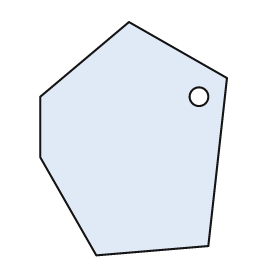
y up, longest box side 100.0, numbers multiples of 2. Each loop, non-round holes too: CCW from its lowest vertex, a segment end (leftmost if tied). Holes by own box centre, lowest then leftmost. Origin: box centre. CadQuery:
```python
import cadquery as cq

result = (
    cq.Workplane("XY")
    .moveTo(-16.0, -50.0)
    .lineTo(32.0, -46.0)
    .lineTo(40.0, 26.0)
    .lineTo(-2.0, 50.0)
    .lineTo(-40.0, 18.0)
    .lineTo(-40.0, -8.0)
    .close()
    .moveTo(28.0, 18.0)
    .circle(4.0)
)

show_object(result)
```